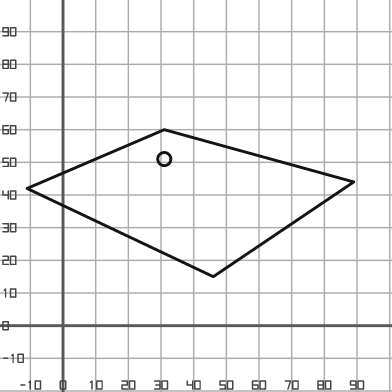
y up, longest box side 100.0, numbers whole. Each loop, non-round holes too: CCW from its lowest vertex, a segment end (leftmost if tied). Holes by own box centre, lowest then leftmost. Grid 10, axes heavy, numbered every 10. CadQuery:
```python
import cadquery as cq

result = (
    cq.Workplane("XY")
    .moveTo(46.0, 15.0)
    .lineTo(89.0, 44.0)
    .lineTo(31.0, 60.0)
    .lineTo(-11.0, 42.0)
    .close()
    .moveTo(31.0, 51.0)
    .circle(2.0)
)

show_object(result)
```